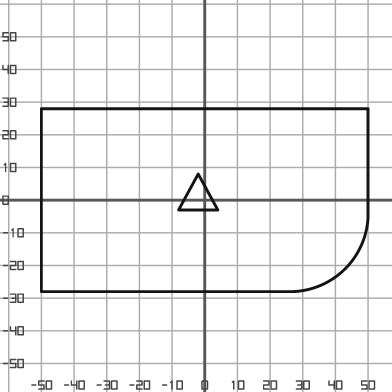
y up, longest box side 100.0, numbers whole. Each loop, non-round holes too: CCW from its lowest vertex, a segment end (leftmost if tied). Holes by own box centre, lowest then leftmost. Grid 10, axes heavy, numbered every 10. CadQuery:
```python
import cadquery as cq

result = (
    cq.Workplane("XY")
    .moveTo(-50.0, -28.0)
    .lineTo(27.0, -28.0)
    .threePointArc((43.0, -21.0), (50.0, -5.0))
    .lineTo(50.0, 28.0)
    .lineTo(-50.0, 28.0)
    .close()
    .moveTo(-8.0, -3.0)
    .lineTo(4.0, -3.0)
    .lineTo(-2.0, 8.0)
    .close()
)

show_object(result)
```